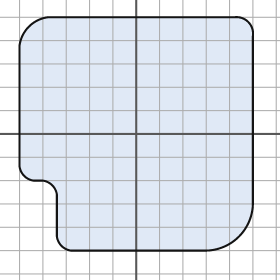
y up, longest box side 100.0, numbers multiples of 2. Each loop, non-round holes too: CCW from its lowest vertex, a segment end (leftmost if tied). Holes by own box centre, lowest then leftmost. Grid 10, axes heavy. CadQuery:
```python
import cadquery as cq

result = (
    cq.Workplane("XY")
    .moveTo(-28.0, -50.0)
    .lineTo(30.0, -50.0)
    .threePointArc((44.0, -44.0), (50.0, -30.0))
    .lineTo(50.0, 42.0)
    .threePointArc((48.0, 48.0), (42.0, 50.0))
    .lineTo(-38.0, 50.0)
    .threePointArc((-46.0, 46.0), (-50.0, 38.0))
    .lineTo(-50.0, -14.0)
    .threePointArc((-48.0, -18.0), (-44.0, -20.0))
    .lineTo(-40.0, -20.0)
    .threePointArc((-36.0, -22.0), (-34.0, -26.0))
    .lineTo(-34.0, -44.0)
    .threePointArc((-32.0, -48.0), (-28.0, -50.0))
    .close()
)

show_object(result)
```